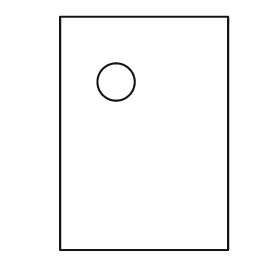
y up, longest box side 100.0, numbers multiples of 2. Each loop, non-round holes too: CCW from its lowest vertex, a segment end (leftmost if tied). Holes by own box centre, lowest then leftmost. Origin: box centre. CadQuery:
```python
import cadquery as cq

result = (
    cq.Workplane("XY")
    .moveTo(-36.0, -50.0)
    .lineTo(36.0, -50.0)
    .lineTo(36.0, 50.0)
    .lineTo(-36.0, 50.0)
    .close()
    .moveTo(-12.0, 22.0)
    .circle(8.0)
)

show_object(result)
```